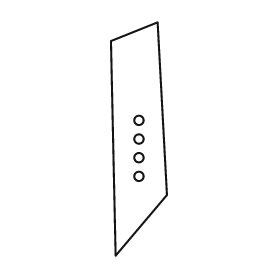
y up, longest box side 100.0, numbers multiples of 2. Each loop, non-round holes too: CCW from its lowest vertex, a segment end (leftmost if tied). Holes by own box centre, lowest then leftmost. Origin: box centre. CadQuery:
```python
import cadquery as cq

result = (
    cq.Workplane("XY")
    .moveTo(-10.0, -50.0)
    .lineTo(12.0, -24.0)
    .lineTo(8.0, 50.0)
    .lineTo(-12.0, 42.0)
    .close()
    .moveTo(0.0, -16.0)
    .circle(2.0)
    .moveTo(0.0, -8.0)
    .circle(2.0)
    .moveTo(0.0, 0.0)
    .circle(2.0)
    .moveTo(0.0, 8.0)
    .circle(2.0)
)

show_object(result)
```